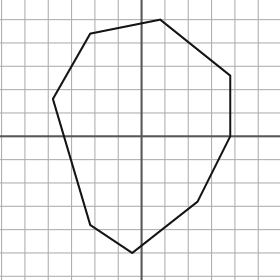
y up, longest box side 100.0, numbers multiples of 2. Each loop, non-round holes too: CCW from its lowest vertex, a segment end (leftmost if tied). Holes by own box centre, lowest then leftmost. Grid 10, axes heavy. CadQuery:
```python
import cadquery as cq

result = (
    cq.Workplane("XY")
    .moveTo(-4.0, -50.0)
    .lineTo(24.0, -28.0)
    .lineTo(38.0, 0.0)
    .lineTo(38.0, 26.0)
    .lineTo(8.0, 50.0)
    .lineTo(-22.0, 44.0)
    .lineTo(-38.0, 16.0)
    .lineTo(-22.0, -38.0)
    .close()
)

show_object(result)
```